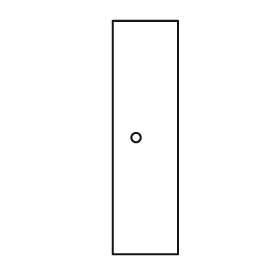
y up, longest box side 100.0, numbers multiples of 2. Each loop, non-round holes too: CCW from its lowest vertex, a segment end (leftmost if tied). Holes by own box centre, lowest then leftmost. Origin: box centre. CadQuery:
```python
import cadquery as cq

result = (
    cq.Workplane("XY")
    .moveTo(-14.0, -50.0)
    .lineTo(14.0, -50.0)
    .lineTo(14.0, 50.0)
    .lineTo(-14.0, 50.0)
    .close()
    .moveTo(-4.0, 0.0)
    .circle(2.0)
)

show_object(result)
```